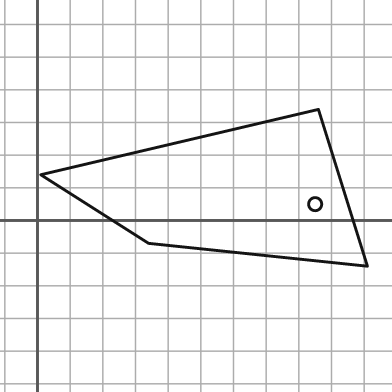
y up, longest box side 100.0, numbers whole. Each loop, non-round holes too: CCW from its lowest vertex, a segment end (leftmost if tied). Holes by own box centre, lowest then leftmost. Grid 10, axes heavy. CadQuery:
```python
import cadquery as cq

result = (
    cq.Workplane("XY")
    .moveTo(101.0, -14.0)
    .lineTo(86.0, 34.0)
    .lineTo(1.0, 14.0)
    .lineTo(34.0, -7.0)
    .close()
    .moveTo(85.0, 5.0)
    .circle(2.0)
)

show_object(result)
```